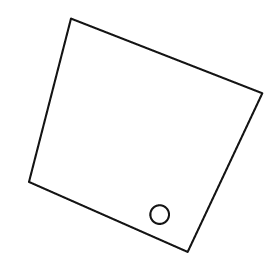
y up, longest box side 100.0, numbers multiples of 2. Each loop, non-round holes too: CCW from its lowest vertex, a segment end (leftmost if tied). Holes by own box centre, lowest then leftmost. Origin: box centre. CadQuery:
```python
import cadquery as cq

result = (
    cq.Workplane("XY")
    .moveTo(18.0, -50.0)
    .lineTo(50.0, 18.0)
    .lineTo(-32.0, 50.0)
    .lineTo(-50.0, -20.0)
    .close()
    .moveTo(6.0, -34.0)
    .circle(4.0)
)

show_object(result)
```